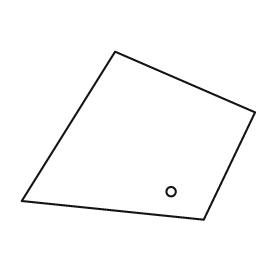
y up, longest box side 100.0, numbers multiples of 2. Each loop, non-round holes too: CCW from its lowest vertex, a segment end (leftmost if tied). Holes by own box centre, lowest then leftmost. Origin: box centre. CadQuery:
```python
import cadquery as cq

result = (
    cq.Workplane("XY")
    .moveTo(28.0, -36.0)
    .lineTo(50.0, 10.0)
    .lineTo(-10.0, 36.0)
    .lineTo(-50.0, -28.0)
    .close()
    .moveTo(14.0, -24.0)
    .circle(2.0)
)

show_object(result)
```